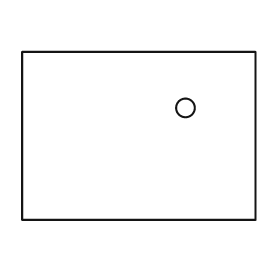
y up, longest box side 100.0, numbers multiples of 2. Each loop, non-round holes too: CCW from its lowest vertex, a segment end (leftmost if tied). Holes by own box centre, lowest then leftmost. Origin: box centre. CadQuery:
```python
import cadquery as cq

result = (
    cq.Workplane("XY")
    .moveTo(-50.0, -36.0)
    .lineTo(50.0, -36.0)
    .lineTo(50.0, 36.0)
    .lineTo(-50.0, 36.0)
    .close()
    .moveTo(20.0, 12.0)
    .circle(4.0)
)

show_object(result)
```